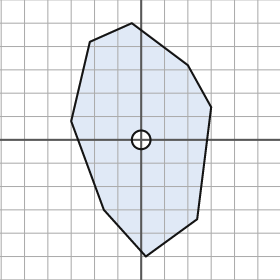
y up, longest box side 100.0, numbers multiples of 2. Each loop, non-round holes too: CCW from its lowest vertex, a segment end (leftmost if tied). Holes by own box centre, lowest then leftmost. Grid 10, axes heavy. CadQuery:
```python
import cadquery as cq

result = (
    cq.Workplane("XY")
    .moveTo(2.0, -50.0)
    .lineTo(24.0, -34.0)
    .lineTo(30.0, 14.0)
    .lineTo(20.0, 32.0)
    .lineTo(-4.0, 50.0)
    .lineTo(-22.0, 42.0)
    .lineTo(-30.0, 8.0)
    .lineTo(-16.0, -30.0)
    .close()
    .moveTo(0.0, 0.0)
    .circle(4.0)
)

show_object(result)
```